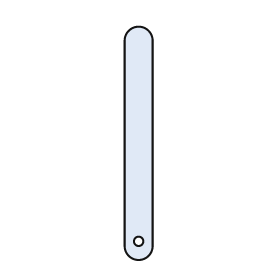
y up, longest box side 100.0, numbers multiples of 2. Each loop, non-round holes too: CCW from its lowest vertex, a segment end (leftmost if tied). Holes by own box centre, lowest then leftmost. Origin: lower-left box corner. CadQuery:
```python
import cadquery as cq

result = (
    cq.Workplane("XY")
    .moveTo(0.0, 6.0)
    .threePointArc((6.0, 0.0), (12.0, 6.0))
    .lineTo(12.0, 94.0)
    .threePointArc((6.0, 100.0), (0.0, 94.0))
    .close()
    .moveTo(6.0, 8.0)
    .circle(2.0)
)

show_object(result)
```